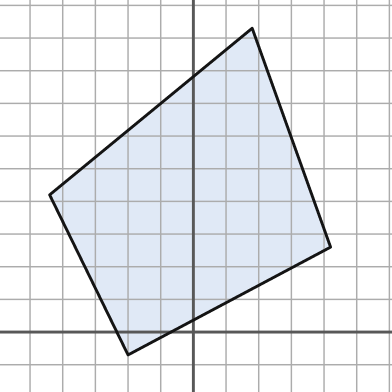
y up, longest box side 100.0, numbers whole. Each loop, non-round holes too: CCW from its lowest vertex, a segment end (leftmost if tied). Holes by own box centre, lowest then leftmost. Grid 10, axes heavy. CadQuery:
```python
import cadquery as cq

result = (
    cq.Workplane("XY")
    .moveTo(-20.0, -7.0)
    .lineTo(42.0, 26.0)
    .lineTo(18.0, 93.0)
    .lineTo(-44.0, 42.0)
    .close()
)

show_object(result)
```